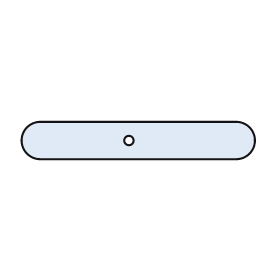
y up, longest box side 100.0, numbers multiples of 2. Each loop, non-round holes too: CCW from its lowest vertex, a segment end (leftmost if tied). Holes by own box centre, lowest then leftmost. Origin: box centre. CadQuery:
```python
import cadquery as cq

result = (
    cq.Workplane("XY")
    .moveTo(-42.0, -8.0)
    .lineTo(42.0, -8.0)
    .threePointArc((50.0, 0.0), (42.0, 8.0))
    .lineTo(-42.0, 8.0)
    .threePointArc((-50.0, 0.0), (-42.0, -8.0))
    .close()
    .moveTo(-4.0, 0.0)
    .circle(2.0)
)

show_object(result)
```